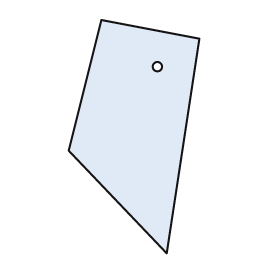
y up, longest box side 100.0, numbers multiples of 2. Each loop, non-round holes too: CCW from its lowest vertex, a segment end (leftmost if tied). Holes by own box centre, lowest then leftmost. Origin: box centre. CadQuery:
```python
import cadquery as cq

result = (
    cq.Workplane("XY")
    .moveTo(14.0, -50.0)
    .lineTo(28.0, 42.0)
    .lineTo(-14.0, 50.0)
    .lineTo(-28.0, -6.0)
    .close()
    .moveTo(10.0, 30.0)
    .circle(2.0)
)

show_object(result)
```